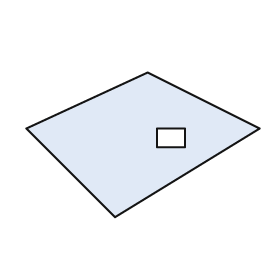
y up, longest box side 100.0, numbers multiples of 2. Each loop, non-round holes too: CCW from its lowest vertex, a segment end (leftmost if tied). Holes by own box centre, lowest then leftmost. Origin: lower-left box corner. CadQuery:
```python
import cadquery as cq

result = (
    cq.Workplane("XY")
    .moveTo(38.0, 0.0)
    .lineTo(100.0, 38.0)
    .lineTo(52.0, 62.0)
    .lineTo(0.0, 38.0)
    .close()
    .moveTo(56.0, 30.0)
    .lineTo(68.0, 30.0)
    .lineTo(68.0, 38.0)
    .lineTo(56.0, 38.0)
    .close()
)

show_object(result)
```